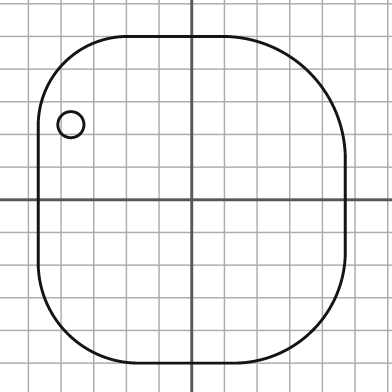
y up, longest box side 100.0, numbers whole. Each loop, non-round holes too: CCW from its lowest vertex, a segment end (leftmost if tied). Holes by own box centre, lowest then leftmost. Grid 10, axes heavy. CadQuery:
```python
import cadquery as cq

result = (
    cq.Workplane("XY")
    .moveTo(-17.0, -50.0)
    .lineTo(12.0, -50.0)
    .threePointArc((37.0, -40.0), (47.0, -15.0))
    .lineTo(47.0, 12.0)
    .threePointArc((36.0, 39.0), (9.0, 50.0))
    .lineTo(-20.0, 50.0)
    .threePointArc((-39.0, 42.0), (-47.0, 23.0))
    .lineTo(-47.0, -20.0)
    .threePointArc((-38.0, -41.0), (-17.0, -50.0))
    .close()
    .moveTo(-37.0, 23.0)
    .circle(4.0)
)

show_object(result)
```